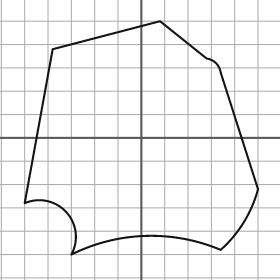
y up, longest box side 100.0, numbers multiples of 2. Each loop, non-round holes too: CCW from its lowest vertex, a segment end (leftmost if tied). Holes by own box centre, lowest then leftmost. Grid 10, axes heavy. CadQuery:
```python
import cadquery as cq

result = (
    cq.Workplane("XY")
    .moveTo(-30.0, -50.0)
    .threePointArc((2.0, -42.0), (34.0, -48.0))
    .threePointArc((44.0, -36.0), (50.0, -22.0))
    .lineTo(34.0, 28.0)
    .threePointArc((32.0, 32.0), (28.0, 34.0))
    .lineTo(8.0, 50.0)
    .lineTo(-38.0, 38.0)
    .lineTo(-50.0, -28.0)
    .threePointArc((-32.0, -32.0), (-30.0, -50.0))
    .close()
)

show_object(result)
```